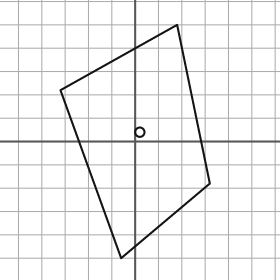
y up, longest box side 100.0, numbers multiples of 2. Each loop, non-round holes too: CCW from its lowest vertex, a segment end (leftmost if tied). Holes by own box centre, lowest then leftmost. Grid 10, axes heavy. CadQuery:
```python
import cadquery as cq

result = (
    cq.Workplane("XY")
    .moveTo(-6.0, -50.0)
    .lineTo(32.0, -18.0)
    .lineTo(18.0, 50.0)
    .lineTo(-32.0, 22.0)
    .close()
    .moveTo(2.0, 4.0)
    .circle(2.0)
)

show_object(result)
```